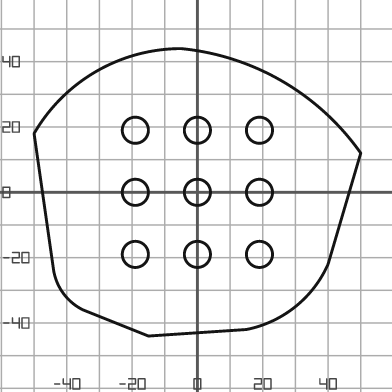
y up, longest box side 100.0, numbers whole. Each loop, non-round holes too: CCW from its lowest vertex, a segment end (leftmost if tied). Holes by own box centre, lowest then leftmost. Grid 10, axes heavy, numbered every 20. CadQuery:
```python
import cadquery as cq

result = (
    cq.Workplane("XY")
    .moveTo(-15.0, -44.0)
    .lineTo(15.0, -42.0)
    .threePointArc((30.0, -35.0), (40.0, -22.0))
    .lineTo(50.0, 12.0)
    .threePointArc((26.0, 34.0), (-5.0, 44.0))
    .threePointArc((-31.0, 37.0), (-50.0, 18.0))
    .lineTo(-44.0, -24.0)
    .threePointArc((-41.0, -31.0), (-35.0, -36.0))
    .close()
    .moveTo(-19.0, -19.0)
    .circle(4.0)
    .moveTo(0.0, -19.0)
    .circle(4.0)
    .moveTo(19.0, -19.0)
    .circle(4.0)
    .moveTo(-19.0, 0.0)
    .circle(4.0)
    .moveTo(0.0, 0.0)
    .circle(4.0)
    .moveTo(19.0, 0.0)
    .circle(4.0)
    .moveTo(-19.0, 19.0)
    .circle(4.0)
    .moveTo(0.0, 19.0)
    .circle(4.0)
    .moveTo(19.0, 19.0)
    .circle(4.0)
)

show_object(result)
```